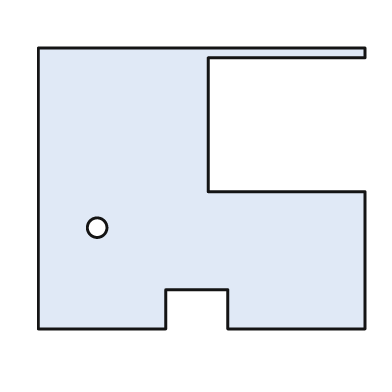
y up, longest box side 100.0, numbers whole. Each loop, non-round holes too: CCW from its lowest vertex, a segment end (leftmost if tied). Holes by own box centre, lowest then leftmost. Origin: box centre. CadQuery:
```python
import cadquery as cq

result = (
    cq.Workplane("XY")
    .moveTo(-50.0, -43.0)
    .lineTo(-11.0, -43.0)
    .lineTo(-11.0, -31.0)
    .lineTo(8.0, -31.0)
    .lineTo(8.0, -43.0)
    .lineTo(50.0, -43.0)
    .lineTo(50.0, -1.0)
    .lineTo(2.0, -1.0)
    .lineTo(2.0, 40.0)
    .lineTo(50.0, 40.0)
    .lineTo(50.0, 43.0)
    .lineTo(-50.0, 43.0)
    .close()
    .moveTo(-32.0, -12.0)
    .circle(3.0)
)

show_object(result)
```